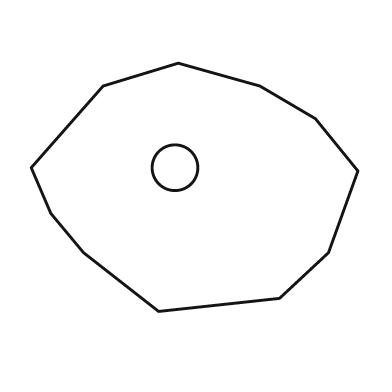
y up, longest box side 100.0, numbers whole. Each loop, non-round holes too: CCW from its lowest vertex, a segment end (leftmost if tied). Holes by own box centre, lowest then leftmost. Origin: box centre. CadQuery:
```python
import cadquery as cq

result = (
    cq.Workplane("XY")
    .moveTo(-11.0, -38.0)
    .lineTo(26.0, -34.0)
    .lineTo(41.0, -20.0)
    .lineTo(50.0, 5.0)
    .lineTo(37.0, 21.0)
    .lineTo(20.0, 31.0)
    .lineTo(-5.0, 38.0)
    .lineTo(-28.0, 31.0)
    .lineTo(-50.0, 6.0)
    .lineTo(-44.0, -8.0)
    .lineTo(-34.0, -20.0)
    .close()
    .moveTo(-6.0, 6.0)
    .circle(7.0)
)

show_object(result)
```